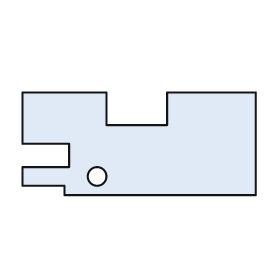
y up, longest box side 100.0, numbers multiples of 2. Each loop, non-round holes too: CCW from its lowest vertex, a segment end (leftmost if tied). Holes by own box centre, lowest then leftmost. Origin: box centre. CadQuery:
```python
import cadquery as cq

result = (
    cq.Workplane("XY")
    .moveTo(-32.0, -22.0)
    .lineTo(50.0, -22.0)
    .lineTo(50.0, 22.0)
    .lineTo(12.0, 22.0)
    .lineTo(12.0, 8.0)
    .lineTo(-14.0, 8.0)
    .lineTo(-14.0, 22.0)
    .lineTo(-50.0, 22.0)
    .lineTo(-50.0, 0.0)
    .lineTo(-30.0, 0.0)
    .lineTo(-30.0, -10.0)
    .lineTo(-50.0, -10.0)
    .lineTo(-50.0, -18.0)
    .lineTo(-32.0, -18.0)
    .close()
    .moveTo(-18.0, -14.0)
    .circle(4.0)
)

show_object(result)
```